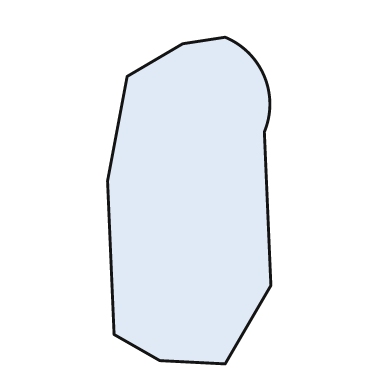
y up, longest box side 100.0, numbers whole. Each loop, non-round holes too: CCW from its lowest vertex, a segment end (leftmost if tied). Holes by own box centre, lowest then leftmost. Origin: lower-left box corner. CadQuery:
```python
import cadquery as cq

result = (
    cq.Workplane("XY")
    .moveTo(36.0, 0.0)
    .lineTo(50.0, 24.0)
    .lineTo(48.0, 71.0)
    .threePointArc((48.0, 88.0), (36.0, 100.0))
    .lineTo(23.0, 98.0)
    .lineTo(6.0, 88.0)
    .lineTo(0.0, 56.0)
    .lineTo(2.0, 9.0)
    .lineTo(16.0, 1.0)
    .close()
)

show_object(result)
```